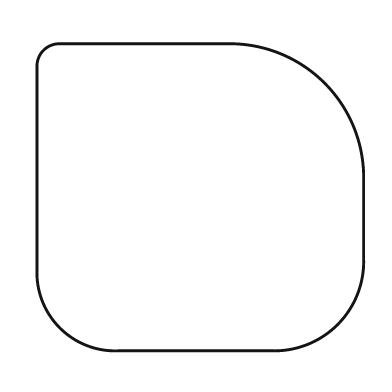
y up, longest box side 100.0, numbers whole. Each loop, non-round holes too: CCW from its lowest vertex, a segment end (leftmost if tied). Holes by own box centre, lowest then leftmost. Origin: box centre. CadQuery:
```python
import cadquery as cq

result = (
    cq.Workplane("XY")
    .moveTo(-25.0, -47.0)
    .lineTo(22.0, -47.0)
    .threePointArc((42.0, -39.0), (50.0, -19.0))
    .lineTo(50.0, 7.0)
    .threePointArc((38.0, 35.0), (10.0, 47.0))
    .lineTo(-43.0, 47.0)
    .threePointArc((-48.0, 45.0), (-50.0, 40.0))
    .lineTo(-50.0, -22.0)
    .threePointArc((-43.0, -40.0), (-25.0, -47.0))
    .close()
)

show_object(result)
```